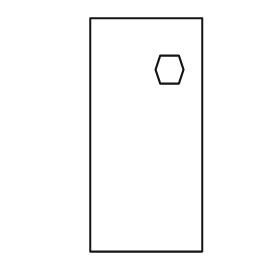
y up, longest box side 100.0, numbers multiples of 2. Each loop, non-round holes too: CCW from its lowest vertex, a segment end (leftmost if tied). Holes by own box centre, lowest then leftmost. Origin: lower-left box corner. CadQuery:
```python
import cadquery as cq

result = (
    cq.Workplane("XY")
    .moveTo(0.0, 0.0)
    .lineTo(48.0, 0.0)
    .lineTo(48.0, 100.0)
    .lineTo(0.0, 100.0)
    .close()
    .moveTo(30.0, 72.0)
    .lineTo(38.0, 72.0)
    .lineTo(40.0, 78.0)
    .lineTo(38.0, 84.0)
    .lineTo(30.0, 84.0)
    .lineTo(28.0, 78.0)
    .close()
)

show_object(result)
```